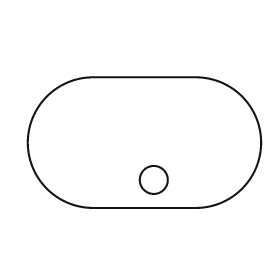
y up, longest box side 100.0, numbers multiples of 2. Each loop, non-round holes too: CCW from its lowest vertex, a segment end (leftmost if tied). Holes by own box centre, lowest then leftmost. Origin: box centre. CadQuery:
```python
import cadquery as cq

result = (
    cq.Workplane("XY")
    .moveTo(-22.0, -28.0)
    .lineTo(22.0, -28.0)
    .threePointArc((50.0, 0.0), (22.0, 28.0))
    .lineTo(-22.0, 28.0)
    .threePointArc((-50.0, 0.0), (-22.0, -28.0))
    .close()
    .moveTo(4.0, -16.0)
    .circle(6.0)
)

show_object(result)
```